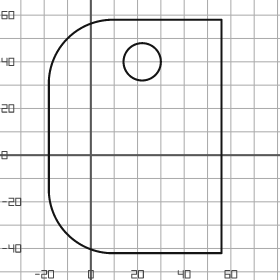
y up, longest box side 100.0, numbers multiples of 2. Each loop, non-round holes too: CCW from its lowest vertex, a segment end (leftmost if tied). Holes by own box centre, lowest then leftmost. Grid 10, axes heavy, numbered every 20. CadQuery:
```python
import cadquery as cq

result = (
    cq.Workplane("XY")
    .moveTo(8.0, -42.0)
    .lineTo(56.0, -42.0)
    .lineTo(56.0, 58.0)
    .lineTo(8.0, 58.0)
    .threePointArc((-10.0, 50.0), (-18.0, 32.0))
    .lineTo(-18.0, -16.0)
    .threePointArc((-10.0, -34.0), (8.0, -42.0))
    .close()
    .moveTo(22.0, 40.0)
    .circle(8.0)
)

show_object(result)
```